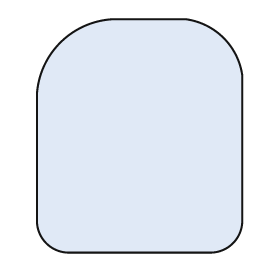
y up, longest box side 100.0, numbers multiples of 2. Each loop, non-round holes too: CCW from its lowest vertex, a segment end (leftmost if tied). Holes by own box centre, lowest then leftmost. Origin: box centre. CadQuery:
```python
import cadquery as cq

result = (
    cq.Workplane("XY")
    .moveTo(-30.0, -50.0)
    .lineTo(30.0, -50.0)
    .threePointArc((40.0, -46.0), (44.0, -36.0))
    .lineTo(44.0, 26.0)
    .threePointArc((36.0, 42.0), (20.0, 50.0))
    .lineTo(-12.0, 50.0)
    .threePointArc((-34.0, 40.0), (-44.0, 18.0))
    .lineTo(-44.0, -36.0)
    .threePointArc((-40.0, -46.0), (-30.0, -50.0))
    .close()
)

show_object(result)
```